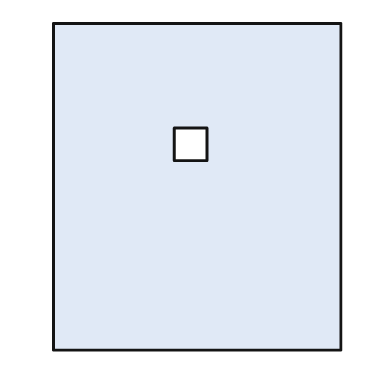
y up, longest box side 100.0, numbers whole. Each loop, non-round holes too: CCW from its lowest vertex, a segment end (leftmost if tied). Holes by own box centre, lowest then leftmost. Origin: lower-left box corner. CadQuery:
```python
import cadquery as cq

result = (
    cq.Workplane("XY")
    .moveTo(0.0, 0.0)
    .lineTo(88.0, 0.0)
    .lineTo(88.0, 100.0)
    .lineTo(0.0, 100.0)
    .close()
    .moveTo(37.0, 58.0)
    .lineTo(47.0, 58.0)
    .lineTo(47.0, 68.0)
    .lineTo(37.0, 68.0)
    .close()
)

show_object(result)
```